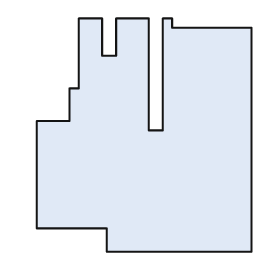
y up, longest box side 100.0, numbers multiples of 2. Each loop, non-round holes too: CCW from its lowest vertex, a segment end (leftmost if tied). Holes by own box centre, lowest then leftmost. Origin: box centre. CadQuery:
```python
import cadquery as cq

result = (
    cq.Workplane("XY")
    .moveTo(-16.0, -50.0)
    .lineTo(46.0, -50.0)
    .lineTo(46.0, 46.0)
    .lineTo(12.0, 46.0)
    .lineTo(12.0, 50.0)
    .lineTo(8.0, 50.0)
    .lineTo(8.0, 2.0)
    .lineTo(2.0, 2.0)
    .lineTo(2.0, 50.0)
    .lineTo(-12.0, 50.0)
    .lineTo(-12.0, 34.0)
    .lineTo(-18.0, 34.0)
    .lineTo(-18.0, 50.0)
    .lineTo(-28.0, 50.0)
    .lineTo(-28.0, 20.0)
    .lineTo(-32.0, 20.0)
    .lineTo(-32.0, 6.0)
    .lineTo(-46.0, 6.0)
    .lineTo(-46.0, -40.0)
    .lineTo(-16.0, -40.0)
    .close()
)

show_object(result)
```